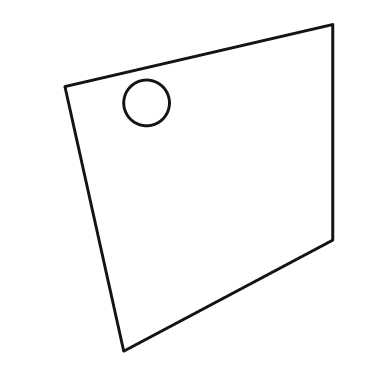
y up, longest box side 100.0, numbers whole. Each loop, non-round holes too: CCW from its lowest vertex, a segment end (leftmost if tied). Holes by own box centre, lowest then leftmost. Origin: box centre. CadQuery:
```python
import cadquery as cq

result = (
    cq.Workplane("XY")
    .moveTo(-23.0, -50.0)
    .lineTo(41.0, -16.0)
    .lineTo(41.0, 50.0)
    .lineTo(-41.0, 31.0)
    .close()
    .moveTo(-16.0, 26.0)
    .circle(7.0)
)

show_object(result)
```